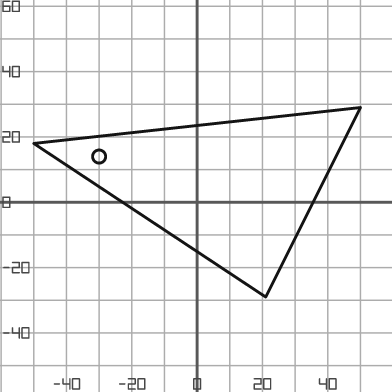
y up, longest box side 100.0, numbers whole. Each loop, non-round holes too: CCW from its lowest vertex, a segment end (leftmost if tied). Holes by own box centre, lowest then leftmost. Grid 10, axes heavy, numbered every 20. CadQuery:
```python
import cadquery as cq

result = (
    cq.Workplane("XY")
    .moveTo(21.0, -29.0)
    .lineTo(50.0, 29.0)
    .lineTo(-50.0, 18.0)
    .close()
    .moveTo(-30.0, 14.0)
    .circle(2.0)
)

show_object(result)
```